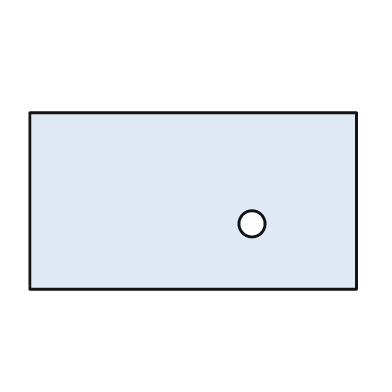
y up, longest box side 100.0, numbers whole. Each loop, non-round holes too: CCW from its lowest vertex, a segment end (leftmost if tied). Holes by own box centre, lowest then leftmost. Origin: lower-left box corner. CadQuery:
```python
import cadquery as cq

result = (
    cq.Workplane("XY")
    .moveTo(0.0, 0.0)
    .lineTo(100.0, 0.0)
    .lineTo(100.0, 54.0)
    .lineTo(0.0, 54.0)
    .close()
    .moveTo(68.0, 20.0)
    .circle(4.0)
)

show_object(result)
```